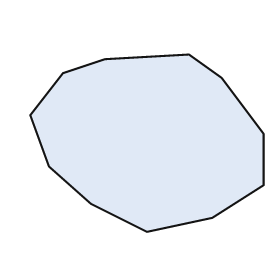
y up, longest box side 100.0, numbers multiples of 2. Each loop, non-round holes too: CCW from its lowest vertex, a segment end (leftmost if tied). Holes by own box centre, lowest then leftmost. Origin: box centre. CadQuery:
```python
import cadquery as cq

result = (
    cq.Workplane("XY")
    .moveTo(0.0, -38.0)
    .lineTo(28.0, -32.0)
    .lineTo(50.0, -18.0)
    .lineTo(50.0, 4.0)
    .lineTo(32.0, 28.0)
    .lineTo(18.0, 38.0)
    .lineTo(-18.0, 36.0)
    .lineTo(-36.0, 30.0)
    .lineTo(-50.0, 12.0)
    .lineTo(-42.0, -10.0)
    .lineTo(-24.0, -26.0)
    .close()
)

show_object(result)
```